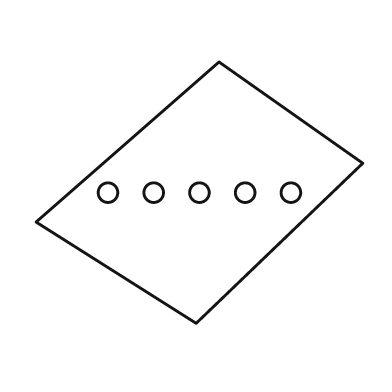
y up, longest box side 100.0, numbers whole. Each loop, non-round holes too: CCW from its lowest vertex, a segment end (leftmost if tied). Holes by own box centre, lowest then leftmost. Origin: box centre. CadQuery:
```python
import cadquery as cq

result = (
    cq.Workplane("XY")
    .moveTo(-1.0, -40.0)
    .lineTo(50.0, 9.0)
    .lineTo(6.0, 40.0)
    .lineTo(-50.0, -9.0)
    .close()
    .moveTo(-28.0, 0.0)
    .circle(3.0)
    .moveTo(-14.0, 0.0)
    .circle(3.0)
    .moveTo(0.0, 0.0)
    .circle(3.0)
    .moveTo(14.0, 0.0)
    .circle(3.0)
    .moveTo(28.0, 0.0)
    .circle(3.0)
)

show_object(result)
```